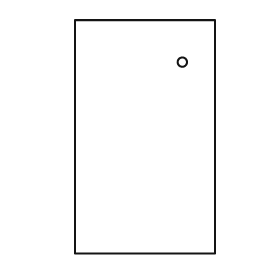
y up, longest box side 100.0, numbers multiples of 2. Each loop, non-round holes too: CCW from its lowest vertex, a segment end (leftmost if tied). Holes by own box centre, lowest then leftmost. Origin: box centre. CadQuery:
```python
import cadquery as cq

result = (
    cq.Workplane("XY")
    .moveTo(-30.0, -50.0)
    .lineTo(30.0, -50.0)
    .lineTo(30.0, 50.0)
    .lineTo(-30.0, 50.0)
    .close()
    .moveTo(16.0, 32.0)
    .circle(2.0)
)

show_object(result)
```